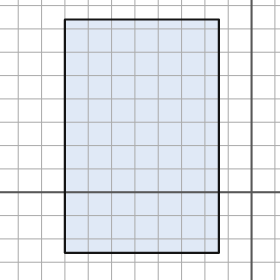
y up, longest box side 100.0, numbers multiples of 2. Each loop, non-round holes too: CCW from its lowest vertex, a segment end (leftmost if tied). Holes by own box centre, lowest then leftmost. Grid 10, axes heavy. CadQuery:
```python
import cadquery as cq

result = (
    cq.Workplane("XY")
    .moveTo(-80.0, -26.0)
    .lineTo(-14.0, -26.0)
    .lineTo(-14.0, 74.0)
    .lineTo(-80.0, 74.0)
    .close()
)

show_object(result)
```